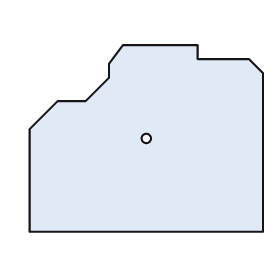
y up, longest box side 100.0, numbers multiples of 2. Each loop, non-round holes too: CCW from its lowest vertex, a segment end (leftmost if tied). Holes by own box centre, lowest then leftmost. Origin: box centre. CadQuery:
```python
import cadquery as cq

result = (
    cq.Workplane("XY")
    .moveTo(-50.0, -40.0)
    .lineTo(50.0, -40.0)
    .lineTo(50.0, 28.0)
    .lineTo(44.0, 34.0)
    .lineTo(22.0, 34.0)
    .lineTo(22.0, 40.0)
    .lineTo(-10.0, 40.0)
    .lineTo(-16.0, 32.0)
    .lineTo(-16.0, 26.0)
    .lineTo(-26.0, 16.0)
    .lineTo(-38.0, 16.0)
    .lineTo(-50.0, 4.0)
    .close()
    .moveTo(0.0, 0.0)
    .circle(2.0)
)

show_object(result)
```